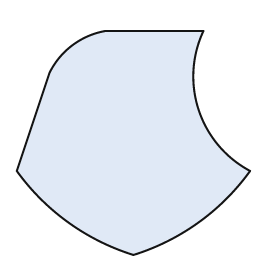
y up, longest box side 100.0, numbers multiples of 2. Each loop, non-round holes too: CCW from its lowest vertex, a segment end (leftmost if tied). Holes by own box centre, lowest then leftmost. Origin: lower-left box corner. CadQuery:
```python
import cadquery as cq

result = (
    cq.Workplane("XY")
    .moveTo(50.0, 0.0)
    .threePointArc((78.0, 14.0), (100.0, 36.0))
    .threePointArc((78.0, 62.0), (80.0, 96.0))
    .lineTo(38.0, 96.0)
    .threePointArc((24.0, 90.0), (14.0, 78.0))
    .lineTo(0.0, 36.0)
    .threePointArc((22.0, 14.0), (50.0, 0.0))
    .close()
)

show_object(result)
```